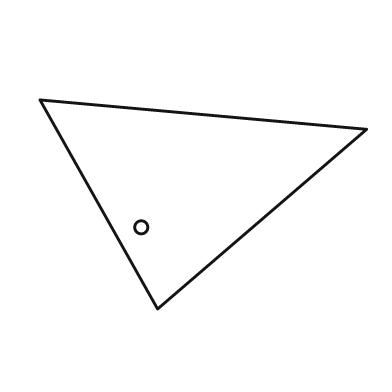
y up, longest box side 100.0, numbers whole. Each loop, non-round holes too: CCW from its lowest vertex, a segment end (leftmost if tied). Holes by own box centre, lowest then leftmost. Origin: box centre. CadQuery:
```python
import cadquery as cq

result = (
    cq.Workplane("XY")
    .moveTo(-14.0, -32.0)
    .lineTo(50.0, 23.0)
    .lineTo(-50.0, 32.0)
    .close()
    .moveTo(-19.0, -7.0)
    .circle(2.0)
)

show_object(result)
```